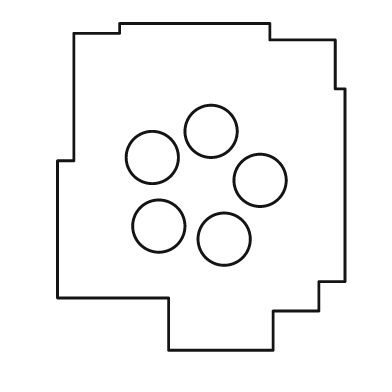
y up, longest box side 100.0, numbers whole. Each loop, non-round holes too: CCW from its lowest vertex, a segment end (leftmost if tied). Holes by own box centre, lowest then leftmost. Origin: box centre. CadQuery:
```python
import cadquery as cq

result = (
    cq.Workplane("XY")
    .moveTo(-10.0, -50.0)
    .lineTo(22.0, -50.0)
    .lineTo(22.0, -38.0)
    .lineTo(36.0, -38.0)
    .lineTo(36.0, -29.0)
    .lineTo(44.0, -29.0)
    .lineTo(44.0, 30.0)
    .lineTo(41.0, 30.0)
    .lineTo(41.0, 45.0)
    .lineTo(21.0, 45.0)
    .lineTo(21.0, 50.0)
    .lineTo(-25.0, 50.0)
    .lineTo(-25.0, 47.0)
    .lineTo(-39.0, 47.0)
    .lineTo(-39.0, 8.0)
    .lineTo(-44.0, 8.0)
    .lineTo(-44.0, -34.0)
    .lineTo(-10.0, -34.0)
    .close()
    .moveTo(7.0, -16.0)
    .circle(8.0)
    .moveTo(-13.0, -12.0)
    .circle(8.0)
    .moveTo(18.0, 2.0)
    .circle(8.0)
    .moveTo(-15.0, 9.0)
    .circle(8.0)
    .moveTo(3.0, 17.0)
    .circle(8.0)
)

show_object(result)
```